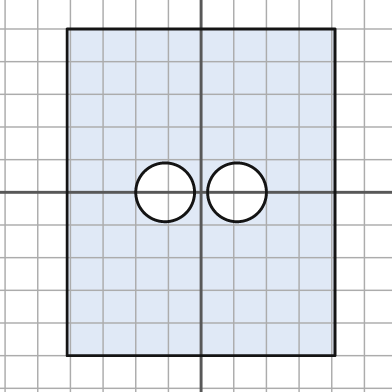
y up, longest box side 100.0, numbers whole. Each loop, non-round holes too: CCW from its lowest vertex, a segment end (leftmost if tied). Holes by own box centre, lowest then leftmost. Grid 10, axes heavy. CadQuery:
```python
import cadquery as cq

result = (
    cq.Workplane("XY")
    .moveTo(-41.0, -50.0)
    .lineTo(41.0, -50.0)
    .lineTo(41.0, 50.0)
    .lineTo(-41.0, 50.0)
    .close()
    .moveTo(-11.0, 0.0)
    .circle(9.0)
    .moveTo(11.0, 0.0)
    .circle(9.0)
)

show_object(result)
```